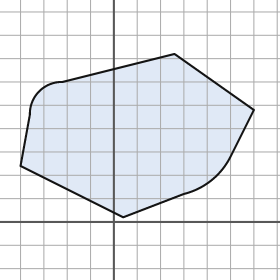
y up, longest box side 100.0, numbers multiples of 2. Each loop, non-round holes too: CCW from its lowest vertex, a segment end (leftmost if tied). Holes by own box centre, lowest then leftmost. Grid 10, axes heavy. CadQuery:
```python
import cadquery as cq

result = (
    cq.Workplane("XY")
    .moveTo(4.0, 2.0)
    .lineTo(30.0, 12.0)
    .threePointArc((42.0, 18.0), (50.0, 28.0))
    .lineTo(60.0, 48.0)
    .lineTo(26.0, 72.0)
    .lineTo(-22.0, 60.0)
    .threePointArc((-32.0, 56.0), (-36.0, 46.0))
    .lineTo(-40.0, 24.0)
    .close()
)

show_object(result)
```